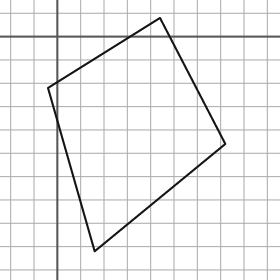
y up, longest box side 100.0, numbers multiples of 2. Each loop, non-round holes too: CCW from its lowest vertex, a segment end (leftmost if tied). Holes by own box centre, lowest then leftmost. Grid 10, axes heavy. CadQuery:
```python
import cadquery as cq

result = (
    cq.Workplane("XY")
    .moveTo(16.0, -92.0)
    .lineTo(72.0, -46.0)
    .lineTo(44.0, 8.0)
    .lineTo(-4.0, -22.0)
    .close()
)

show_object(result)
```